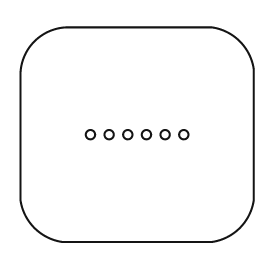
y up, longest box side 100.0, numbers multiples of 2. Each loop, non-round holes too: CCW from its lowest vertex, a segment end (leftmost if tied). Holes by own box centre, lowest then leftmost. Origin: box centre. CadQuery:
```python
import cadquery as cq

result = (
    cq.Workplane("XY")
    .moveTo(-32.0, -46.0)
    .lineTo(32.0, -46.0)
    .threePointArc((44.0, -40.0), (50.0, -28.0))
    .lineTo(50.0, 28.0)
    .threePointArc((44.0, 40.0), (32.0, 46.0))
    .lineTo(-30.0, 46.0)
    .threePointArc((-44.0, 40.0), (-50.0, 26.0))
    .lineTo(-50.0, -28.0)
    .threePointArc((-44.0, -40.0), (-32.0, -46.0))
    .close()
    .moveTo(-20.0, 0.0)
    .circle(2.0)
    .moveTo(-12.0, 0.0)
    .circle(2.0)
    .moveTo(-4.0, 0.0)
    .circle(2.0)
    .moveTo(4.0, 0.0)
    .circle(2.0)
    .moveTo(12.0, 0.0)
    .circle(2.0)
    .moveTo(20.0, 0.0)
    .circle(2.0)
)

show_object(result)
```